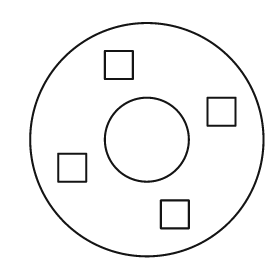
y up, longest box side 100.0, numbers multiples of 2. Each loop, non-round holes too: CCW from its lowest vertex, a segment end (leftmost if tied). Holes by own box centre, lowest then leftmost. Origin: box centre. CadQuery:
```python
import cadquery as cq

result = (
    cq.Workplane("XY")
    .moveTo(0.0, 0.0)
    .circle(50.0)
    .moveTo(6.0, -38.0)
    .lineTo(18.0, -38.0)
    .lineTo(18.0, -26.0)
    .lineTo(6.0, -26.0)
    .close()
    .moveTo(-38.0, -18.0)
    .lineTo(-26.0, -18.0)
    .lineTo(-26.0, -6.0)
    .lineTo(-38.0, -6.0)
    .close()
    .moveTo(0.0, 0.0)
    .circle(18.0)
    .moveTo(26.0, 6.0)
    .lineTo(38.0, 6.0)
    .lineTo(38.0, 18.0)
    .lineTo(26.0, 18.0)
    .close()
    .moveTo(-18.0, 26.0)
    .lineTo(-6.0, 26.0)
    .lineTo(-6.0, 38.0)
    .lineTo(-18.0, 38.0)
    .close()
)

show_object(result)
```